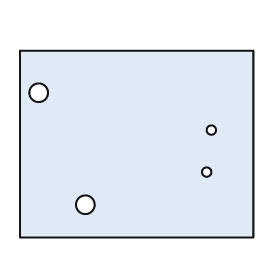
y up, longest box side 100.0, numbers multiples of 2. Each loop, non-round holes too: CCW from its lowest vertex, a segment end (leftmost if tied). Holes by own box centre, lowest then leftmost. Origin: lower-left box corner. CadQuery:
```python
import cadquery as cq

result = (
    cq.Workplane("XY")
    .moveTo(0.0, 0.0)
    .lineTo(100.0, 0.0)
    .lineTo(100.0, 80.0)
    .lineTo(0.0, 80.0)
    .close()
    .moveTo(28.0, 14.0)
    .circle(4.0)
    .moveTo(80.0, 28.0)
    .circle(2.0)
    .moveTo(82.0, 46.0)
    .circle(2.0)
    .moveTo(8.0, 62.0)
    .circle(4.0)
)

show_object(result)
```